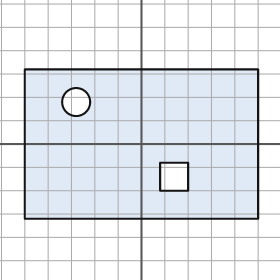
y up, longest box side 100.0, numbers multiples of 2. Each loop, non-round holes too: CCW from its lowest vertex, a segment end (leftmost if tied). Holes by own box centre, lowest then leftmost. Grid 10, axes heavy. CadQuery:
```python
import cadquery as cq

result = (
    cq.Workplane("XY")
    .moveTo(-50.0, -32.0)
    .lineTo(50.0, -32.0)
    .lineTo(50.0, 32.0)
    .lineTo(-50.0, 32.0)
    .close()
    .moveTo(8.0, -20.0)
    .lineTo(20.0, -20.0)
    .lineTo(20.0, -8.0)
    .lineTo(8.0, -8.0)
    .close()
    .moveTo(-28.0, 18.0)
    .circle(6.0)
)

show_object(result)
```